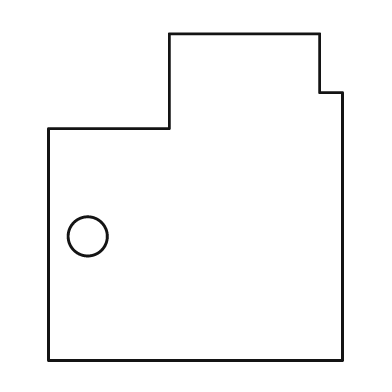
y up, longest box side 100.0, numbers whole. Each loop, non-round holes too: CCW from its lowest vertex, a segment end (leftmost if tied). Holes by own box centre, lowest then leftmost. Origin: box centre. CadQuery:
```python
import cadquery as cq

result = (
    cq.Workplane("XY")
    .moveTo(-45.0, -50.0)
    .lineTo(45.0, -50.0)
    .lineTo(45.0, 32.0)
    .lineTo(38.0, 32.0)
    .lineTo(38.0, 50.0)
    .lineTo(-8.0, 50.0)
    .lineTo(-8.0, 21.0)
    .lineTo(-45.0, 21.0)
    .close()
    .moveTo(-33.0, -12.0)
    .circle(6.0)
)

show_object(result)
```